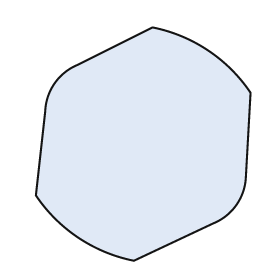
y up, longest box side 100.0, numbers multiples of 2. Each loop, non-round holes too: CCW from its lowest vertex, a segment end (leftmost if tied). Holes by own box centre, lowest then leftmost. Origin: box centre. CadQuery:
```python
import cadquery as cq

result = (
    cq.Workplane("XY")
    .moveTo(-4.0, -50.0)
    .lineTo(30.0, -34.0)
    .threePointArc((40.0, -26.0), (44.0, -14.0))
    .lineTo(46.0, 22.0)
    .threePointArc((28.0, 40.0), (4.0, 50.0))
    .lineTo(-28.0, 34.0)
    .threePointArc((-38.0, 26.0), (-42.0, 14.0))
    .lineTo(-46.0, -22.0)
    .threePointArc((-28.0, -40.0), (-4.0, -50.0))
    .close()
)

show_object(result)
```